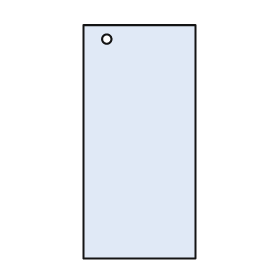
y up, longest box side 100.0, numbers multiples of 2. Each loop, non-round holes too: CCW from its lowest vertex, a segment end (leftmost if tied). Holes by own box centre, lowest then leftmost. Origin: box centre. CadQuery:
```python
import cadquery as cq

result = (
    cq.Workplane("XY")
    .moveTo(-24.0, -50.0)
    .lineTo(24.0, -50.0)
    .lineTo(24.0, 50.0)
    .lineTo(-24.0, 50.0)
    .close()
    .moveTo(-14.0, 44.0)
    .circle(2.0)
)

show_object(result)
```